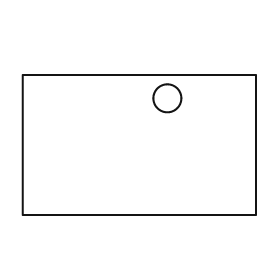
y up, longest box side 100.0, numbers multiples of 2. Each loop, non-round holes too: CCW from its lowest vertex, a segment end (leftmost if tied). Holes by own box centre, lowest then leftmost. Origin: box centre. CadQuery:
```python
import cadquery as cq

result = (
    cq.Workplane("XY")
    .moveTo(-50.0, -30.0)
    .lineTo(50.0, -30.0)
    .lineTo(50.0, 30.0)
    .lineTo(-50.0, 30.0)
    .close()
    .moveTo(12.0, 20.0)
    .circle(6.0)
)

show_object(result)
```